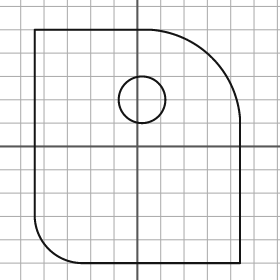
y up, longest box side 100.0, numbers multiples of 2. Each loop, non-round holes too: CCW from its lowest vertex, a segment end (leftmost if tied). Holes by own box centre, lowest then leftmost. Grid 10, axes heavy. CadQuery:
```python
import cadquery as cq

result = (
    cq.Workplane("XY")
    .moveTo(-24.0, -50.0)
    .lineTo(44.0, -50.0)
    .lineTo(44.0, 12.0)
    .threePointArc((32.0, 38.0), (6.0, 50.0))
    .lineTo(-44.0, 50.0)
    .lineTo(-44.0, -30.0)
    .threePointArc((-38.0, -44.0), (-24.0, -50.0))
    .close()
    .moveTo(2.0, 20.0)
    .circle(10.0)
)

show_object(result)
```